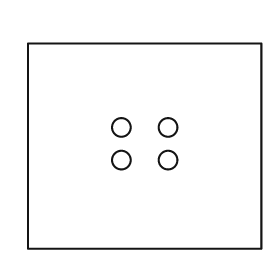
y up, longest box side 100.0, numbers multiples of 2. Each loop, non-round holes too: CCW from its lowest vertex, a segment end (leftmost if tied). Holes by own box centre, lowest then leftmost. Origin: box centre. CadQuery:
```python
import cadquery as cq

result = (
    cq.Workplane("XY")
    .moveTo(-50.0, -44.0)
    .lineTo(50.0, -44.0)
    .lineTo(50.0, 44.0)
    .lineTo(-50.0, 44.0)
    .close()
    .moveTo(-10.0, -6.0)
    .circle(4.0)
    .moveTo(10.0, -6.0)
    .circle(4.0)
    .moveTo(-10.0, 8.0)
    .circle(4.0)
    .moveTo(10.0, 8.0)
    .circle(4.0)
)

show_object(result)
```